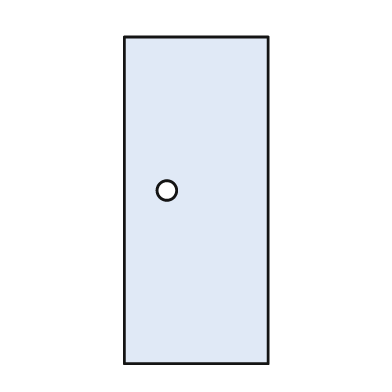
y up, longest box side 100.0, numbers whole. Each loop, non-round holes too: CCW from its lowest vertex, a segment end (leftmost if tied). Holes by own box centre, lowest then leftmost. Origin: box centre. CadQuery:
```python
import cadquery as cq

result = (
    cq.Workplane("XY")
    .moveTo(-22.0, -50.0)
    .lineTo(22.0, -50.0)
    .lineTo(22.0, 50.0)
    .lineTo(-22.0, 50.0)
    .close()
    .moveTo(-9.0, 3.0)
    .circle(3.0)
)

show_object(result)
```